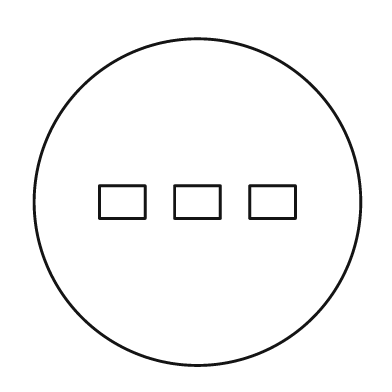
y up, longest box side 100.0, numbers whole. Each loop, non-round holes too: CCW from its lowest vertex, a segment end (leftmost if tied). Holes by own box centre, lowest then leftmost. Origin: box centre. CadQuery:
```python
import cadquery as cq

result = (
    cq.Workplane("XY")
    .moveTo(0.0, 0.0)
    .circle(50.0)
    .moveTo(-30.0, -5.0)
    .lineTo(-16.0, -5.0)
    .lineTo(-16.0, 5.0)
    .lineTo(-30.0, 5.0)
    .close()
    .moveTo(-7.0, -5.0)
    .lineTo(7.0, -5.0)
    .lineTo(7.0, 5.0)
    .lineTo(-7.0, 5.0)
    .close()
    .moveTo(16.0, -5.0)
    .lineTo(30.0, -5.0)
    .lineTo(30.0, 5.0)
    .lineTo(16.0, 5.0)
    .close()
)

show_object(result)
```